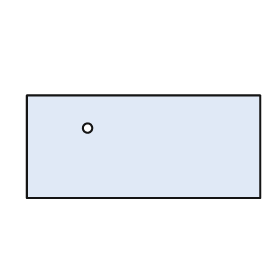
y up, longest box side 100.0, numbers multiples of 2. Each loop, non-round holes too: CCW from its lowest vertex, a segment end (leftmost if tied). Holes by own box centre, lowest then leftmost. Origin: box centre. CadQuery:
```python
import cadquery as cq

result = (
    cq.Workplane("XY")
    .moveTo(-50.0, -22.0)
    .lineTo(50.0, -22.0)
    .lineTo(50.0, 22.0)
    .lineTo(-50.0, 22.0)
    .close()
    .moveTo(-24.0, 8.0)
    .circle(2.0)
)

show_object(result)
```